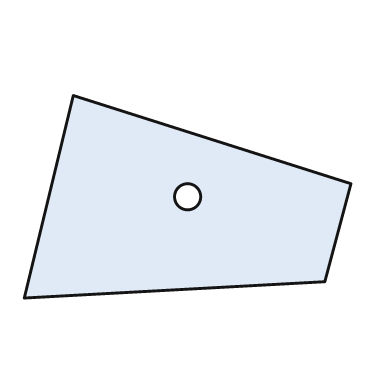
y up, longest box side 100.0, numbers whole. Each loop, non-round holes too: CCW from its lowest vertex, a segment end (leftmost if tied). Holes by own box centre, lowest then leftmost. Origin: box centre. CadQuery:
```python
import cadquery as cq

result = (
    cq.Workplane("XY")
    .moveTo(-50.0, -31.0)
    .lineTo(42.0, -26.0)
    .lineTo(50.0, 4.0)
    .lineTo(-35.0, 31.0)
    .close()
    .moveTo(0.0, 0.0)
    .circle(4.0)
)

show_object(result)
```